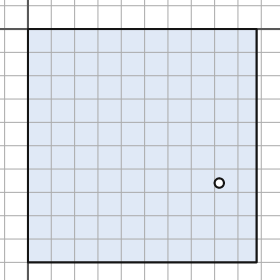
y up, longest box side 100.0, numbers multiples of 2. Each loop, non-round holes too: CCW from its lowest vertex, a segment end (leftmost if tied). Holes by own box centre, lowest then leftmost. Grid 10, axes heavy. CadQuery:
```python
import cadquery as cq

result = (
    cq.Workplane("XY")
    .moveTo(0.0, -100.0)
    .lineTo(98.0, -100.0)
    .lineTo(98.0, 0.0)
    .lineTo(0.0, 0.0)
    .close()
    .moveTo(82.0, -66.0)
    .circle(2.0)
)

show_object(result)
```